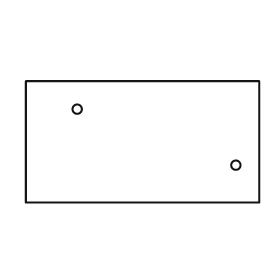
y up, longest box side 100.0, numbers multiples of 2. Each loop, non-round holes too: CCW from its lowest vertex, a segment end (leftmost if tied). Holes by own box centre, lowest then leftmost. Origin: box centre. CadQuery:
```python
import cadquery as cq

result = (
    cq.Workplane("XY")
    .moveTo(-50.0, -26.0)
    .lineTo(50.0, -26.0)
    .lineTo(50.0, 26.0)
    .lineTo(-50.0, 26.0)
    .close()
    .moveTo(40.0, -10.0)
    .circle(2.0)
    .moveTo(-28.0, 14.0)
    .circle(2.0)
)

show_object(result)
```